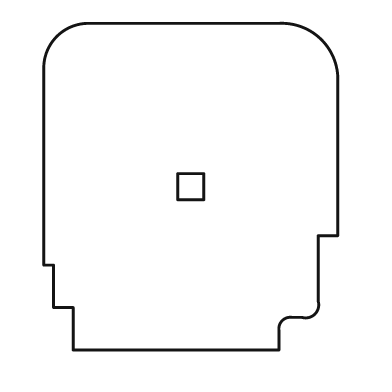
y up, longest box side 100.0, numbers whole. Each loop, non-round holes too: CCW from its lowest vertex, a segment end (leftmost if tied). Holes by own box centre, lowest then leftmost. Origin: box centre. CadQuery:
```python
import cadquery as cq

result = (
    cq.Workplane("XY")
    .moveTo(-36.0, -50.0)
    .lineTo(27.0, -50.0)
    .lineTo(27.0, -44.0)
    .threePointArc((28.0, -41.0), (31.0, -40.0))
    .lineTo(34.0, -40.0)
    .threePointArc((38.0, -39.0), (39.0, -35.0))
    .lineTo(39.0, -15.0)
    .lineTo(45.0, -15.0)
    .lineTo(45.0, 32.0)
    .threePointArc((40.0, 45.0), (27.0, 50.0))
    .lineTo(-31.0, 50.0)
    .threePointArc((-41.0, 46.0), (-45.0, 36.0))
    .lineTo(-45.0, -24.0)
    .lineTo(-42.0, -24.0)
    .lineTo(-42.0, -37.0)
    .lineTo(-36.0, -37.0)
    .close()
    .moveTo(-4.0, -4.0)
    .lineTo(4.0, -4.0)
    .lineTo(4.0, 4.0)
    .lineTo(-4.0, 4.0)
    .close()
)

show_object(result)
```